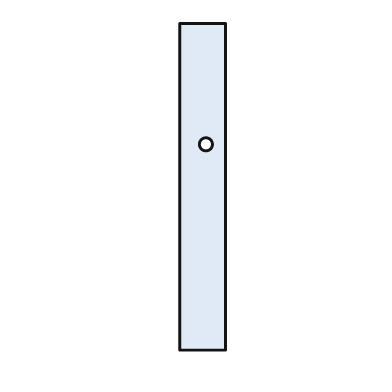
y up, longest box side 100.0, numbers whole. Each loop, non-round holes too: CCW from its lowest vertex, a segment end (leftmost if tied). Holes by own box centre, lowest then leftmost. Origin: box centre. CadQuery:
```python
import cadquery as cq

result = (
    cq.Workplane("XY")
    .moveTo(-7.0, -50.0)
    .lineTo(7.0, -50.0)
    .lineTo(7.0, 50.0)
    .lineTo(-7.0, 50.0)
    .close()
    .moveTo(1.0, 13.0)
    .circle(2.0)
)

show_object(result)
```